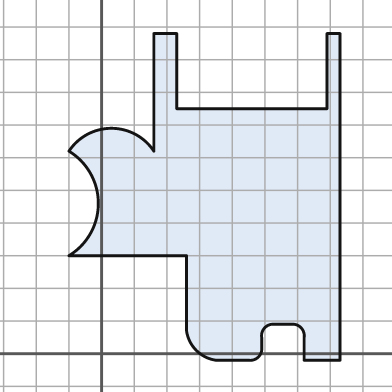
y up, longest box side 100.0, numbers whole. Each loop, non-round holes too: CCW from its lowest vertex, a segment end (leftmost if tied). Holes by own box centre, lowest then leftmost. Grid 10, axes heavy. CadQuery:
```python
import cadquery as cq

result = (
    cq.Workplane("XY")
    .moveTo(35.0, -2.0)
    .lineTo(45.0, -2.0)
    .threePointArc((48.0, -1.0), (49.0, 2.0))
    .lineTo(49.0, 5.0)
    .threePointArc((50.0, 8.0), (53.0, 9.0))
    .lineTo(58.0, 9.0)
    .threePointArc((61.0, 8.0), (62.0, 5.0))
    .lineTo(62.0, -2.0)
    .lineTo(73.0, -2.0)
    .lineTo(73.0, 98.0)
    .lineTo(69.0, 98.0)
    .lineTo(69.0, 75.0)
    .lineTo(23.0, 75.0)
    .lineTo(23.0, 98.0)
    .lineTo(16.0, 98.0)
    .lineTo(16.0, 62.0)
    .threePointArc((3.0, 69.0), (-10.0, 62.0))
    .threePointArc((-1.0, 46.0), (-10.0, 30.0))
    .lineTo(26.0, 30.0)
    .lineTo(26.0, 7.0)
    .threePointArc((29.0, 1.0), (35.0, -2.0))
    .close()
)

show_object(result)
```